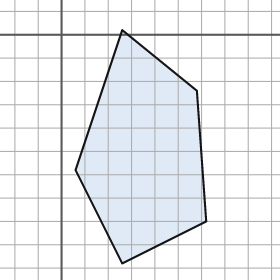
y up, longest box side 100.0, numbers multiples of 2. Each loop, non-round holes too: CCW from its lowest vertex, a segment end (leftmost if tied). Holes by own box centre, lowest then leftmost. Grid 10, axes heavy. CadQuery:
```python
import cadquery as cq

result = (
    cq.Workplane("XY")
    .moveTo(26.0, -98.0)
    .lineTo(62.0, -80.0)
    .lineTo(58.0, -24.0)
    .lineTo(26.0, 2.0)
    .lineTo(6.0, -58.0)
    .close()
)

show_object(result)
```